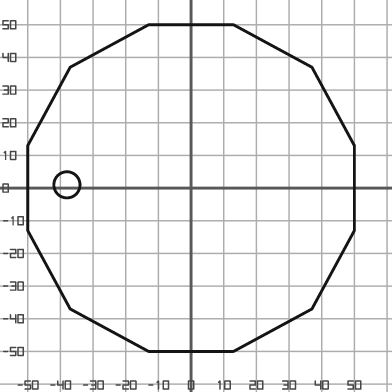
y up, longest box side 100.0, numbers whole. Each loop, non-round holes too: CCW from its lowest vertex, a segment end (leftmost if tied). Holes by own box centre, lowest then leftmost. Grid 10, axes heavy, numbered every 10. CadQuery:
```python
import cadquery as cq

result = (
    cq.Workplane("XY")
    .moveTo(-13.0, -50.0)
    .lineTo(13.0, -50.0)
    .lineTo(37.0, -37.0)
    .lineTo(50.0, -13.0)
    .lineTo(50.0, 13.0)
    .lineTo(37.0, 37.0)
    .lineTo(13.0, 50.0)
    .lineTo(-13.0, 50.0)
    .lineTo(-37.0, 37.0)
    .lineTo(-50.0, 13.0)
    .lineTo(-50.0, -13.0)
    .lineTo(-37.0, -37.0)
    .close()
    .moveTo(-38.0, 1.0)
    .circle(4.0)
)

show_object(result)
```